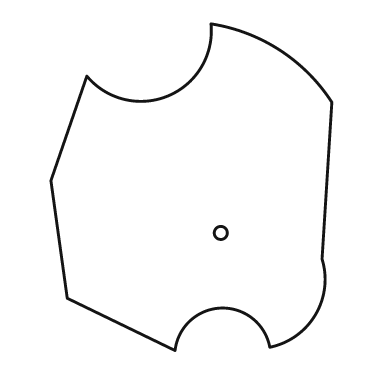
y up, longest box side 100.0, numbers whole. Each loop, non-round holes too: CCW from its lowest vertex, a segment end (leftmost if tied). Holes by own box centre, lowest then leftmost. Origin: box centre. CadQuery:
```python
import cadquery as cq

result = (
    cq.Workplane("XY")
    .moveTo(-5.0, -50.0)
    .threePointArc((9.0, -37.0), (24.0, -49.0))
    .threePointArc((38.0, -39.0), (40.0, -22.0))
    .lineTo(43.0, 26.0)
    .threePointArc((27.0, 42.0), (6.0, 50.0))
    .threePointArc((-7.0, 28.0), (-32.0, 34.0))
    .lineTo(-43.0, 2.0)
    .lineTo(-38.0, -34.0)
    .close()
    .moveTo(9.0, -14.0)
    .circle(2.0)
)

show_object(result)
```